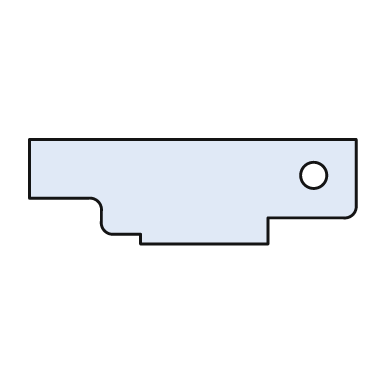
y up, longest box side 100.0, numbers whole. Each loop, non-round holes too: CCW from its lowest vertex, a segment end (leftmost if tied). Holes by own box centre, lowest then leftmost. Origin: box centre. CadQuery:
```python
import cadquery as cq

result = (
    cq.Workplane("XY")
    .moveTo(-16.0, -16.0)
    .lineTo(23.0, -16.0)
    .lineTo(23.0, -8.0)
    .lineTo(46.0, -8.0)
    .threePointArc((49.0, -7.0), (50.0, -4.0))
    .lineTo(50.0, 16.0)
    .lineTo(-50.0, 16.0)
    .lineTo(-50.0, -2.0)
    .lineTo(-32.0, -2.0)
    .threePointArc((-29.0, -3.0), (-28.0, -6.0))
    .lineTo(-28.0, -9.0)
    .threePointArc((-27.0, -12.0), (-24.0, -13.0))
    .lineTo(-16.0, -13.0)
    .close()
    .moveTo(37.0, 5.0)
    .circle(4.0)
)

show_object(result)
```